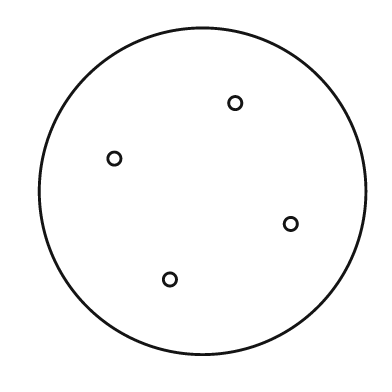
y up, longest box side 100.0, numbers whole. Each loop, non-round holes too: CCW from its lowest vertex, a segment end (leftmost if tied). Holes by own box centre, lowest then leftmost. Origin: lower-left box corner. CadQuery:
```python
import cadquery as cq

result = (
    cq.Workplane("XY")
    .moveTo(50.0, 50.0)
    .circle(50.0)
    .moveTo(40.0, 23.0)
    .circle(2.0)
    .moveTo(77.0, 40.0)
    .circle(2.0)
    .moveTo(23.0, 60.0)
    .circle(2.0)
    .moveTo(60.0, 77.0)
    .circle(2.0)
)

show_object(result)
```